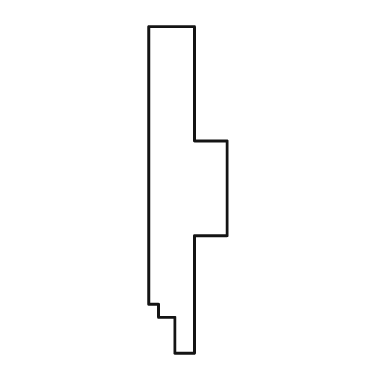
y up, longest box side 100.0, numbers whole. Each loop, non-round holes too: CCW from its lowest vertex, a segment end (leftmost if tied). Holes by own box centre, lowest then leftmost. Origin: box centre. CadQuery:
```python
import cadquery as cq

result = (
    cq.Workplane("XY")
    .moveTo(-4.0, -50.0)
    .lineTo(2.0, -50.0)
    .lineTo(2.0, -14.0)
    .lineTo(12.0, -14.0)
    .lineTo(12.0, 15.0)
    .lineTo(2.0, 15.0)
    .lineTo(2.0, 50.0)
    .lineTo(-12.0, 50.0)
    .lineTo(-12.0, -35.0)
    .lineTo(-9.0, -35.0)
    .lineTo(-9.0, -39.0)
    .lineTo(-4.0, -39.0)
    .close()
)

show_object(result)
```